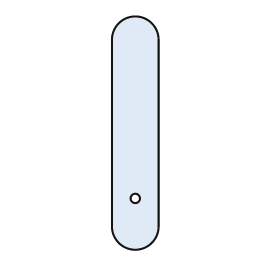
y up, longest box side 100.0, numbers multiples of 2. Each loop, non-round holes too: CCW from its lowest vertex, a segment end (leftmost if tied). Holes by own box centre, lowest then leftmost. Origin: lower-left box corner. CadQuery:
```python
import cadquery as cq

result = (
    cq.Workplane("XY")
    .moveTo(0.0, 10.0)
    .threePointArc((10.0, 0.0), (20.0, 10.0))
    .lineTo(20.0, 90.0)
    .threePointArc((10.0, 100.0), (0.0, 90.0))
    .close()
    .moveTo(10.0, 22.0)
    .circle(2.0)
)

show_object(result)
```